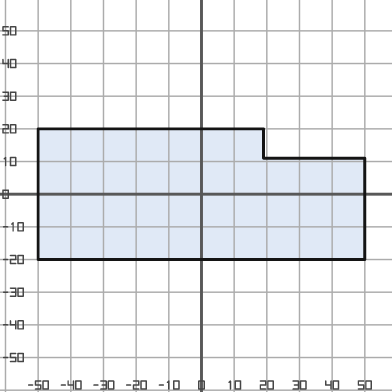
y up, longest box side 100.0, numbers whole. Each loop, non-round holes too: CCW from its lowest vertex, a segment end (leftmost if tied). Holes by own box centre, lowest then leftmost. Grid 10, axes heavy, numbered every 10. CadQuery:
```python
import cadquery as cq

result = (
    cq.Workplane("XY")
    .moveTo(-50.0, -20.0)
    .lineTo(50.0, -20.0)
    .lineTo(50.0, 11.0)
    .lineTo(19.0, 11.0)
    .lineTo(19.0, 20.0)
    .lineTo(-50.0, 20.0)
    .close()
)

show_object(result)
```